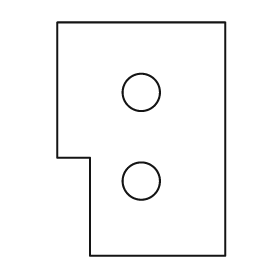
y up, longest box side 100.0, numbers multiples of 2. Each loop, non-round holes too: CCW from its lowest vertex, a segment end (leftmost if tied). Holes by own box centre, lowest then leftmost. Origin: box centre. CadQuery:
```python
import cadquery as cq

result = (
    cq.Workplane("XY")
    .moveTo(-22.0, -50.0)
    .lineTo(36.0, -50.0)
    .lineTo(36.0, 50.0)
    .lineTo(-36.0, 50.0)
    .lineTo(-36.0, -8.0)
    .lineTo(-22.0, -8.0)
    .close()
    .moveTo(0.0, -18.0)
    .circle(8.0)
    .moveTo(0.0, 20.0)
    .circle(8.0)
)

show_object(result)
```